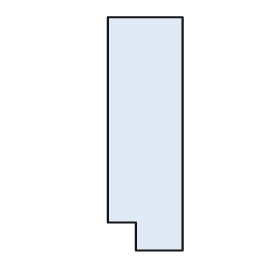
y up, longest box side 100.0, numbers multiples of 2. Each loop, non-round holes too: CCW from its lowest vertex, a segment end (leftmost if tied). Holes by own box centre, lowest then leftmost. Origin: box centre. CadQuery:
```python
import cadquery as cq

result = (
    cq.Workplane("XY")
    .moveTo(-4.0, -50.0)
    .lineTo(16.0, -50.0)
    .lineTo(16.0, 50.0)
    .lineTo(-16.0, 50.0)
    .lineTo(-16.0, -38.0)
    .lineTo(-4.0, -38.0)
    .close()
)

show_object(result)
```